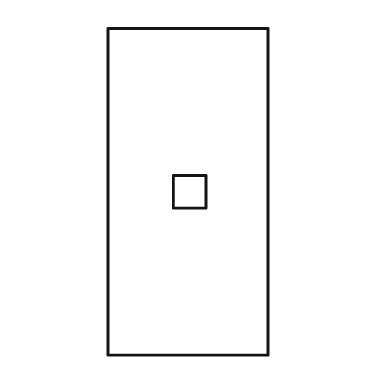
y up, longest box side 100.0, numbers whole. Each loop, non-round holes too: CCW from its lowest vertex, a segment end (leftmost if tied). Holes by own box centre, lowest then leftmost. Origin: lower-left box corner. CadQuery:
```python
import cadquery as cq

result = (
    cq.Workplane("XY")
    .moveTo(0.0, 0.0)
    .lineTo(49.0, 0.0)
    .lineTo(49.0, 100.0)
    .lineTo(0.0, 100.0)
    .close()
    .moveTo(20.0, 45.0)
    .lineTo(30.0, 45.0)
    .lineTo(30.0, 55.0)
    .lineTo(20.0, 55.0)
    .close()
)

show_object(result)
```